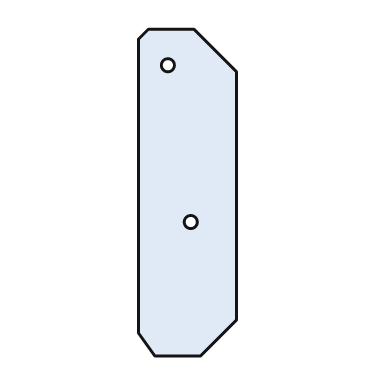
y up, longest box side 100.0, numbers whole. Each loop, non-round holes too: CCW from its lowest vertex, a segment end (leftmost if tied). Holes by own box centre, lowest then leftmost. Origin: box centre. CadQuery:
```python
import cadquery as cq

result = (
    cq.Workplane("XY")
    .moveTo(-10.0, -50.0)
    .lineTo(4.0, -50.0)
    .lineTo(15.0, -39.0)
    .lineTo(15.0, 37.0)
    .lineTo(2.0, 50.0)
    .lineTo(-12.0, 50.0)
    .lineTo(-15.0, 47.0)
    .lineTo(-15.0, -43.0)
    .close()
    .moveTo(1.0, -9.0)
    .circle(2.0)
    .moveTo(-6.0, 39.0)
    .circle(2.0)
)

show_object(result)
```